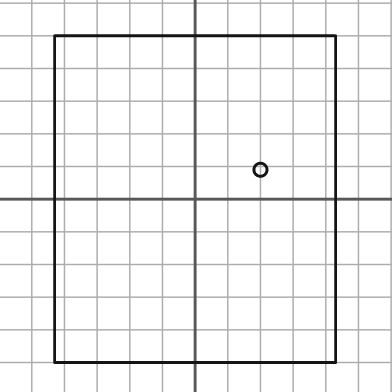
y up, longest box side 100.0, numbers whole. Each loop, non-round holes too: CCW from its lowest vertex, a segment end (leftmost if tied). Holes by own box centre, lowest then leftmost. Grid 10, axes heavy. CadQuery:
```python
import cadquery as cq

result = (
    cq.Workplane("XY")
    .moveTo(-43.0, -50.0)
    .lineTo(43.0, -50.0)
    .lineTo(43.0, 50.0)
    .lineTo(-43.0, 50.0)
    .close()
    .moveTo(20.0, 9.0)
    .circle(2.0)
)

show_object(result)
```